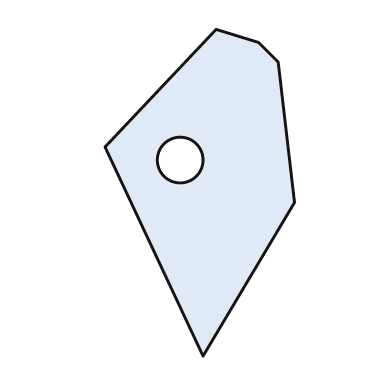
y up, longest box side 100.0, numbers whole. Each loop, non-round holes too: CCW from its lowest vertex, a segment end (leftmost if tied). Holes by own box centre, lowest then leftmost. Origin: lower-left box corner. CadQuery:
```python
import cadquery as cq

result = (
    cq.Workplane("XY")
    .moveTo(30.0, 0.0)
    .lineTo(58.0, 47.0)
    .lineTo(53.0, 90.0)
    .lineTo(47.0, 96.0)
    .lineTo(34.0, 100.0)
    .lineTo(0.0, 64.0)
    .close()
    .moveTo(23.0, 60.0)
    .circle(7.0)
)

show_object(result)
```